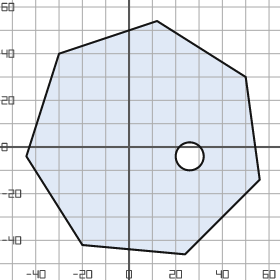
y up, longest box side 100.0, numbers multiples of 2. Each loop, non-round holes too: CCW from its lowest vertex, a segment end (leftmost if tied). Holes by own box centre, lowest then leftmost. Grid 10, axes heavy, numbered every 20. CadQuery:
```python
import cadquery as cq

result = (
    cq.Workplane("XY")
    .moveTo(24.0, -46.0)
    .lineTo(56.0, -14.0)
    .lineTo(50.0, 30.0)
    .lineTo(12.0, 54.0)
    .lineTo(-30.0, 40.0)
    .lineTo(-44.0, -4.0)
    .lineTo(-20.0, -42.0)
    .close()
    .moveTo(26.0, -4.0)
    .circle(6.0)
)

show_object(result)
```